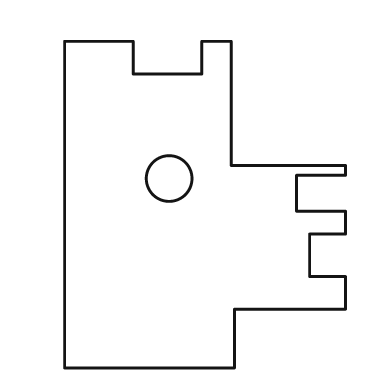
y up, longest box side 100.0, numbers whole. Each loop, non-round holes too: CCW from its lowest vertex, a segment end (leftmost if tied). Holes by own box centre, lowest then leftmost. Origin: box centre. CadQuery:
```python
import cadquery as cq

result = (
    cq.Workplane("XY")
    .moveTo(-43.0, -50.0)
    .lineTo(9.0, -50.0)
    .lineTo(9.0, -32.0)
    .lineTo(43.0, -32.0)
    .lineTo(43.0, -22.0)
    .lineTo(32.0, -22.0)
    .lineTo(32.0, -9.0)
    .lineTo(43.0, -9.0)
    .lineTo(43.0, -2.0)
    .lineTo(28.0, -2.0)
    .lineTo(28.0, 9.0)
    .lineTo(43.0, 9.0)
    .lineTo(43.0, 12.0)
    .lineTo(8.0, 12.0)
    .lineTo(8.0, 50.0)
    .lineTo(-1.0, 50.0)
    .lineTo(-1.0, 40.0)
    .lineTo(-22.0, 40.0)
    .lineTo(-22.0, 50.0)
    .lineTo(-43.0, 50.0)
    .close()
    .moveTo(-11.0, 8.0)
    .circle(7.0)
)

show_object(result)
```